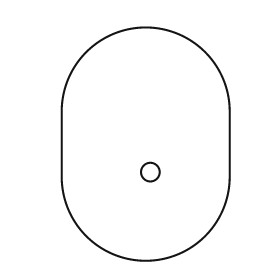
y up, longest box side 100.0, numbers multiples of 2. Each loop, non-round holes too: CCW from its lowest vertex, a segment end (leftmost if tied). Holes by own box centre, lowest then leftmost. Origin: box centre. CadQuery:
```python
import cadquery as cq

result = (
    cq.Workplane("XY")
    .moveTo(-36.0, -14.0)
    .threePointArc((0.0, -50.0), (36.0, -14.0))
    .lineTo(36.0, 14.0)
    .threePointArc((0.0, 50.0), (-36.0, 14.0))
    .close()
    .moveTo(2.0, -12.0)
    .circle(4.0)
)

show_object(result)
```